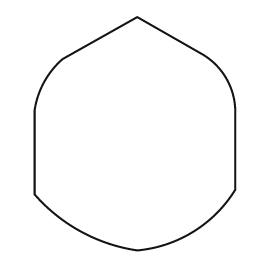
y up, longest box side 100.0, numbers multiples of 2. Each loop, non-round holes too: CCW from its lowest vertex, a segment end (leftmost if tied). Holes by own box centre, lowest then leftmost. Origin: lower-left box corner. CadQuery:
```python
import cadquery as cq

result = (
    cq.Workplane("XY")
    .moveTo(44.0, 0.0)
    .threePointArc((68.0, 8.0), (86.0, 26.0))
    .lineTo(86.0, 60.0)
    .threePointArc((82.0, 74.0), (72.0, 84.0))
    .lineTo(44.0, 100.0)
    .lineTo(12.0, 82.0)
    .threePointArc((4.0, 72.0), (0.0, 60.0))
    .lineTo(0.0, 24.0)
    .threePointArc((20.0, 8.0), (44.0, 0.0))
    .close()
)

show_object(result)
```